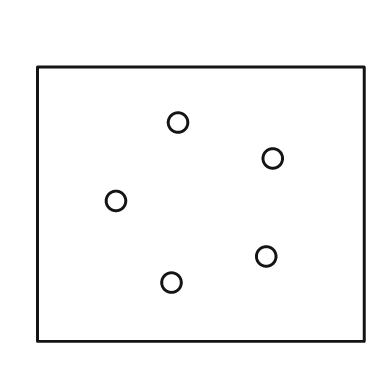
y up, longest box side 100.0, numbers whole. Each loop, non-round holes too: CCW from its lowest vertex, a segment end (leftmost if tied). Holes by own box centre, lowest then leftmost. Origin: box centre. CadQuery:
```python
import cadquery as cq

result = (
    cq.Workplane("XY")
    .moveTo(-50.0, -42.0)
    .lineTo(50.0, -42.0)
    .lineTo(50.0, 42.0)
    .lineTo(-50.0, 42.0)
    .close()
    .moveTo(-9.0, -24.0)
    .circle(3.0)
    .moveTo(20.0, -16.0)
    .circle(3.0)
    .moveTo(-26.0, 1.0)
    .circle(3.0)
    .moveTo(22.0, 14.0)
    .circle(3.0)
    .moveTo(-7.0, 25.0)
    .circle(3.0)
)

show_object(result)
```